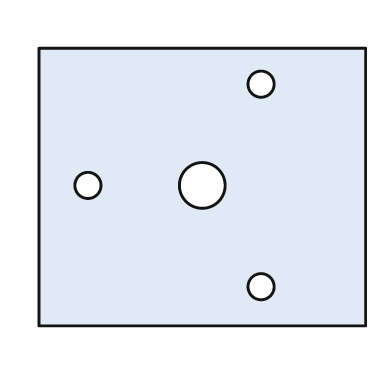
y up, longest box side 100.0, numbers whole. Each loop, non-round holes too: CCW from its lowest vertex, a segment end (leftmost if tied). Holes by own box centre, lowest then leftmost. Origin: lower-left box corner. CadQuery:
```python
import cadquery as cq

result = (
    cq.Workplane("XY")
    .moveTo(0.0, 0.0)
    .lineTo(100.0, 0.0)
    .lineTo(100.0, 85.0)
    .lineTo(0.0, 85.0)
    .close()
    .moveTo(68.0, 12.0)
    .circle(4.0)
    .moveTo(15.0, 43.0)
    .circle(4.0)
    .moveTo(50.0, 43.0)
    .circle(7.0)
    .moveTo(68.0, 74.0)
    .circle(4.0)
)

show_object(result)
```